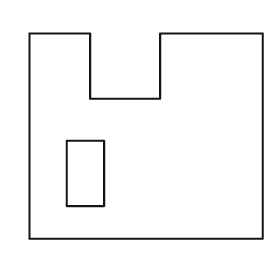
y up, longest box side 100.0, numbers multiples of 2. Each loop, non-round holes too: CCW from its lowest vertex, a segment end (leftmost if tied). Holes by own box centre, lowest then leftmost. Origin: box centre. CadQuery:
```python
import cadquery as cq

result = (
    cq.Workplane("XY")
    .moveTo(-50.0, -44.0)
    .lineTo(50.0, -44.0)
    .lineTo(50.0, 44.0)
    .lineTo(6.0, 44.0)
    .lineTo(6.0, 16.0)
    .lineTo(-24.0, 16.0)
    .lineTo(-24.0, 44.0)
    .lineTo(-50.0, 44.0)
    .close()
    .moveTo(-34.0, -30.0)
    .lineTo(-18.0, -30.0)
    .lineTo(-18.0, -2.0)
    .lineTo(-34.0, -2.0)
    .close()
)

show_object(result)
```